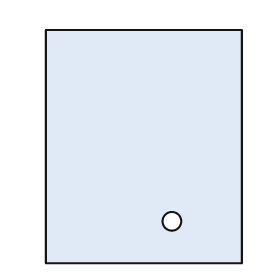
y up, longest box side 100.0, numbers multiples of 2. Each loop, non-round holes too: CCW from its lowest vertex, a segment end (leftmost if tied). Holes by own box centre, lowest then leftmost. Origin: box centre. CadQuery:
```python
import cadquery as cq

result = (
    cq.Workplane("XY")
    .moveTo(-42.0, -50.0)
    .lineTo(42.0, -50.0)
    .lineTo(42.0, 50.0)
    .lineTo(-42.0, 50.0)
    .close()
    .moveTo(12.0, -32.0)
    .circle(4.0)
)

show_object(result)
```